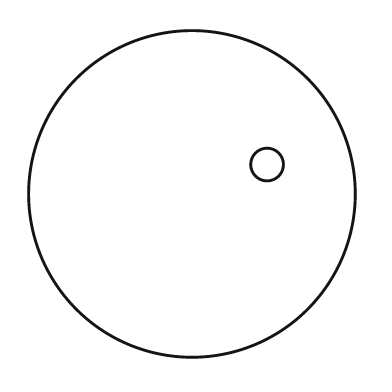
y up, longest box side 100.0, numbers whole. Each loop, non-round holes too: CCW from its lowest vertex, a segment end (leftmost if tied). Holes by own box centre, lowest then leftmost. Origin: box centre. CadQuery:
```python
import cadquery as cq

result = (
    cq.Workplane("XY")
    .moveTo(0.0, 0.0)
    .circle(50.0)
    .moveTo(23.0, 9.0)
    .circle(5.0)
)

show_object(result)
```